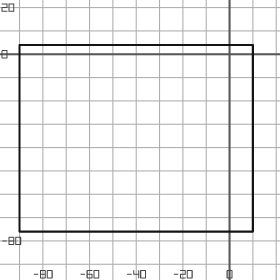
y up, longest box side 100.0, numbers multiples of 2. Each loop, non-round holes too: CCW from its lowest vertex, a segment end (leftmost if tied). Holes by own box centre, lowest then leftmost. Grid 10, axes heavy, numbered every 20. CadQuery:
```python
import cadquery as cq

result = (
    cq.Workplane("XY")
    .moveTo(-90.0, -76.0)
    .lineTo(10.0, -76.0)
    .lineTo(10.0, 4.0)
    .lineTo(-90.0, 4.0)
    .close()
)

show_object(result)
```